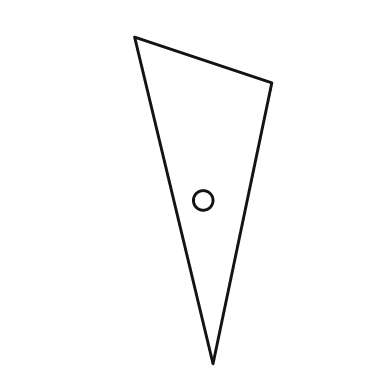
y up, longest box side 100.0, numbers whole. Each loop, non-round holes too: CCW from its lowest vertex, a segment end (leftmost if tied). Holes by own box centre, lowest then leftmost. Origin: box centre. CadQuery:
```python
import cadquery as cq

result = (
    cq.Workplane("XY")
    .moveTo(3.0, -50.0)
    .lineTo(21.0, 36.0)
    .lineTo(-21.0, 50.0)
    .close()
    .moveTo(0.0, 0.0)
    .circle(3.0)
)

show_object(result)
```